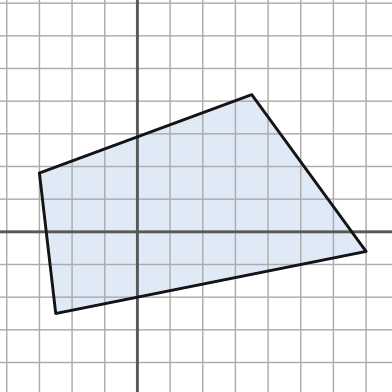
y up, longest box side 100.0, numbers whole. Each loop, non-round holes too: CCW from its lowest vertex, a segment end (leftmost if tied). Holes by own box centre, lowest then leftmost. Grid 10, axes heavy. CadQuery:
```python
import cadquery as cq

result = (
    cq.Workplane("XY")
    .moveTo(-25.0, -25.0)
    .lineTo(70.0, -6.0)
    .lineTo(35.0, 42.0)
    .lineTo(-30.0, 18.0)
    .close()
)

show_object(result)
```